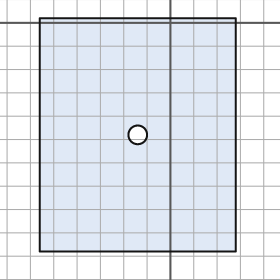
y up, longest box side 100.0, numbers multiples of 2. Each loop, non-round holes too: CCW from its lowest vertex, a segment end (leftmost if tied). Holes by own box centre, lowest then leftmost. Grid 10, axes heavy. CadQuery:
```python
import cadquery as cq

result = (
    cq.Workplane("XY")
    .moveTo(-56.0, -98.0)
    .lineTo(28.0, -98.0)
    .lineTo(28.0, 2.0)
    .lineTo(-56.0, 2.0)
    .close()
    .moveTo(-14.0, -48.0)
    .circle(4.0)
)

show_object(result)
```